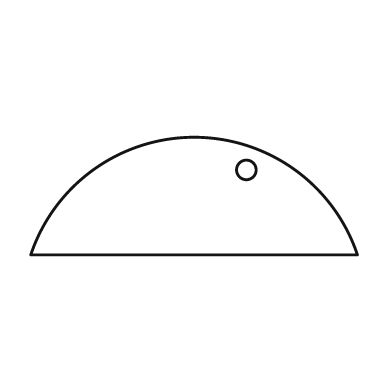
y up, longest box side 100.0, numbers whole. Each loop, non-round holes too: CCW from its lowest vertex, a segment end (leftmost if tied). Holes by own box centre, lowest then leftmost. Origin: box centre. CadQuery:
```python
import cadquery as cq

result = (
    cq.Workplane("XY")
    .moveTo(-50.0, -18.0)
    .lineTo(50.0, -18.0)
    .threePointArc((0.0, 18.0), (-50.0, -18.0))
    .close()
    .moveTo(16.0, 8.0)
    .circle(3.0)
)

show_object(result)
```